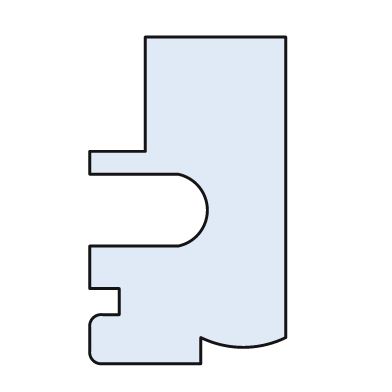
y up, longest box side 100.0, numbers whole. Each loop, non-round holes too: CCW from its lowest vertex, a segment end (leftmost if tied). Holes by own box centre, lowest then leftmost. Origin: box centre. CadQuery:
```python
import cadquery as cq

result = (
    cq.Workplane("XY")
    .moveTo(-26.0, -50.0)
    .lineTo(4.0, -50.0)
    .lineTo(4.0, -42.0)
    .threePointArc((17.0, -45.0), (30.0, -42.0))
    .lineTo(30.0, 50.0)
    .lineTo(-13.0, 50.0)
    .lineTo(-13.0, 15.0)
    .lineTo(-30.0, 15.0)
    .lineTo(-30.0, 8.0)
    .lineTo(-3.0, 8.0)
    .threePointArc((6.0, -3.0), (-3.0, -14.0))
    .lineTo(-30.0, -14.0)
    .lineTo(-30.0, -27.0)
    .lineTo(-21.0, -27.0)
    .lineTo(-21.0, -35.0)
    .lineTo(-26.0, -35.0)
    .threePointArc((-29.0, -36.0), (-30.0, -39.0))
    .lineTo(-30.0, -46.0)
    .threePointArc((-29.0, -49.0), (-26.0, -50.0))
    .close()
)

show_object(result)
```